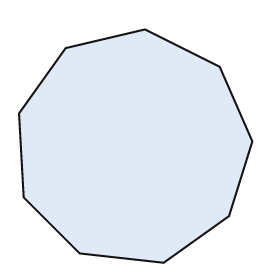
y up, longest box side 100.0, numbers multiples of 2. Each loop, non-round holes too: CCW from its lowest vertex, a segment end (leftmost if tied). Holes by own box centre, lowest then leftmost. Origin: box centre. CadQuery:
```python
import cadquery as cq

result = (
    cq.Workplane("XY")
    .moveTo(12.0, -50.0)
    .lineTo(40.0, -30.0)
    .lineTo(50.0, 2.0)
    .lineTo(36.0, 34.0)
    .lineTo(4.0, 50.0)
    .lineTo(-30.0, 42.0)
    .lineTo(-50.0, 14.0)
    .lineTo(-48.0, -22.0)
    .lineTo(-24.0, -46.0)
    .close()
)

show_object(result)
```